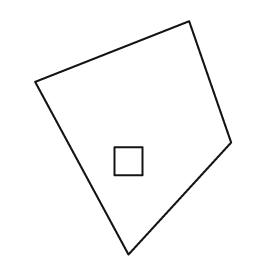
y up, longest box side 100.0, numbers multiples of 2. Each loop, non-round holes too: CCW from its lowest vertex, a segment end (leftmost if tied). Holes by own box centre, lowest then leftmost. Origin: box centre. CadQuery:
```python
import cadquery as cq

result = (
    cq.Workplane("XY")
    .moveTo(-2.0, -50.0)
    .lineTo(42.0, -2.0)
    .lineTo(24.0, 50.0)
    .lineTo(-42.0, 24.0)
    .close()
    .moveTo(-8.0, -16.0)
    .lineTo(4.0, -16.0)
    .lineTo(4.0, -4.0)
    .lineTo(-8.0, -4.0)
    .close()
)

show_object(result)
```